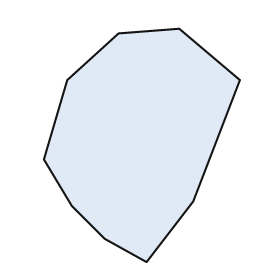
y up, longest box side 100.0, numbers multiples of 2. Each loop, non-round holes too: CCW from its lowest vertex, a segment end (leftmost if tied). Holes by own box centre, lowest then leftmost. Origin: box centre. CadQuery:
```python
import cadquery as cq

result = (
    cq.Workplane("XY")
    .moveTo(2.0, -50.0)
    .lineTo(22.0, -24.0)
    .lineTo(42.0, 28.0)
    .lineTo(16.0, 50.0)
    .lineTo(-10.0, 48.0)
    .lineTo(-32.0, 28.0)
    .lineTo(-42.0, -6.0)
    .lineTo(-30.0, -26.0)
    .lineTo(-16.0, -40.0)
    .close()
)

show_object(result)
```